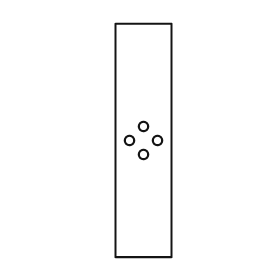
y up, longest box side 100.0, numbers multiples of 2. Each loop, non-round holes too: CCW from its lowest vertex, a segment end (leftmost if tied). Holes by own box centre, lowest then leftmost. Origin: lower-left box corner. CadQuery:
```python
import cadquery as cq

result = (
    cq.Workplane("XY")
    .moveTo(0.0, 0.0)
    .lineTo(24.0, 0.0)
    .lineTo(24.0, 100.0)
    .lineTo(0.0, 100.0)
    .close()
    .moveTo(12.0, 44.0)
    .circle(2.0)
    .moveTo(6.0, 50.0)
    .circle(2.0)
    .moveTo(18.0, 50.0)
    .circle(2.0)
    .moveTo(12.0, 56.0)
    .circle(2.0)
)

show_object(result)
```